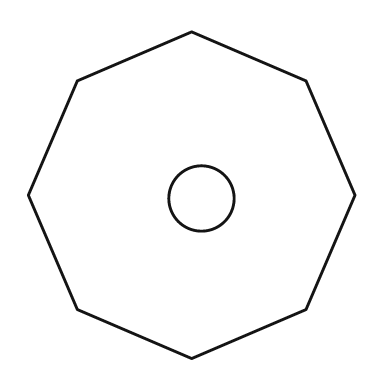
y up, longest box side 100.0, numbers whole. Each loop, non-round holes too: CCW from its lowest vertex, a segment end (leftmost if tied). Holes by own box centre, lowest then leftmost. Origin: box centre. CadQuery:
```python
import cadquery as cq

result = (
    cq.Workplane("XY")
    .moveTo(0.0, -50.0)
    .lineTo(35.0, -35.0)
    .lineTo(50.0, 0.0)
    .lineTo(35.0, 35.0)
    .lineTo(0.0, 50.0)
    .lineTo(-35.0, 35.0)
    .lineTo(-50.0, 0.0)
    .lineTo(-35.0, -35.0)
    .close()
    .moveTo(3.0, -1.0)
    .circle(10.0)
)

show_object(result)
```